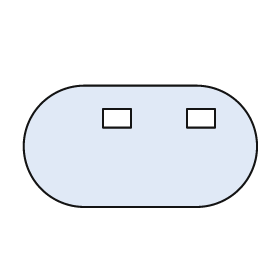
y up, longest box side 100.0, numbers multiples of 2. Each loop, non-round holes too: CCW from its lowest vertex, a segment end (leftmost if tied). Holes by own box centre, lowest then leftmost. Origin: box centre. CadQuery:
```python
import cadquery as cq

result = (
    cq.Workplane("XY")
    .moveTo(-24.0, -26.0)
    .lineTo(24.0, -26.0)
    .threePointArc((50.0, 0.0), (24.0, 26.0))
    .lineTo(-24.0, 26.0)
    .threePointArc((-50.0, 0.0), (-24.0, -26.0))
    .close()
    .moveTo(-16.0, 8.0)
    .lineTo(-4.0, 8.0)
    .lineTo(-4.0, 16.0)
    .lineTo(-16.0, 16.0)
    .close()
    .moveTo(20.0, 8.0)
    .lineTo(32.0, 8.0)
    .lineTo(32.0, 16.0)
    .lineTo(20.0, 16.0)
    .close()
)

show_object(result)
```